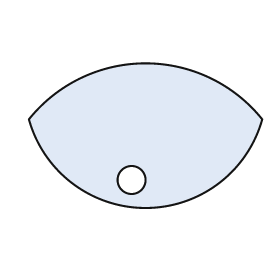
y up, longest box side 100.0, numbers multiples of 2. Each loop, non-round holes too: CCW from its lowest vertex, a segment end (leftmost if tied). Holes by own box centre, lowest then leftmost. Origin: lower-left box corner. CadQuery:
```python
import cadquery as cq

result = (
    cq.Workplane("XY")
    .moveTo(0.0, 38.0)
    .threePointArc((50.0, 0.0), (100.0, 38.0))
    .threePointArc((50.0, 62.0), (0.0, 38.0))
    .close()
    .moveTo(44.0, 12.0)
    .circle(6.0)
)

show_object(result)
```